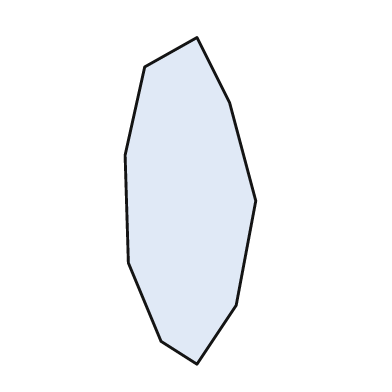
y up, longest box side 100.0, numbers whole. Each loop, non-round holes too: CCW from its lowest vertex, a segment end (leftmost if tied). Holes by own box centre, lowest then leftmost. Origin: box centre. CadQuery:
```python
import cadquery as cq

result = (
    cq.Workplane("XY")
    .moveTo(2.0, -50.0)
    .lineTo(14.0, -32.0)
    .lineTo(20.0, 0.0)
    .lineTo(12.0, 30.0)
    .lineTo(2.0, 50.0)
    .lineTo(-14.0, 41.0)
    .lineTo(-20.0, 14.0)
    .lineTo(-19.0, -19.0)
    .lineTo(-9.0, -43.0)
    .close()
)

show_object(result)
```